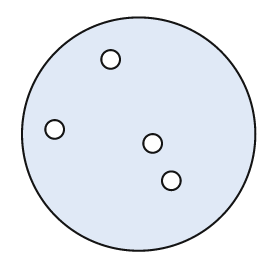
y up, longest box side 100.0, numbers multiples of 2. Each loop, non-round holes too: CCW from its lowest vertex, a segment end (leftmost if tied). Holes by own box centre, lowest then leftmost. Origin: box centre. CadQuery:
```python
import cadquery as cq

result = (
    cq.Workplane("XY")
    .moveTo(0.0, 0.0)
    .circle(50.0)
    .moveTo(14.0, -20.0)
    .circle(4.0)
    .moveTo(6.0, -4.0)
    .circle(4.0)
    .moveTo(-36.0, 2.0)
    .circle(4.0)
    .moveTo(-12.0, 32.0)
    .circle(4.0)
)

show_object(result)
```